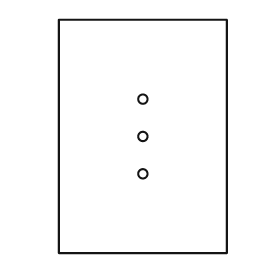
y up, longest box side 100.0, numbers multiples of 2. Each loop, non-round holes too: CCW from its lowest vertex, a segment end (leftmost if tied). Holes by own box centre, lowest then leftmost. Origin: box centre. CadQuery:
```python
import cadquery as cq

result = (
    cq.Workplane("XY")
    .moveTo(-36.0, -50.0)
    .lineTo(36.0, -50.0)
    .lineTo(36.0, 50.0)
    .lineTo(-36.0, 50.0)
    .close()
    .moveTo(0.0, -16.0)
    .circle(2.0)
    .moveTo(0.0, 0.0)
    .circle(2.0)
    .moveTo(0.0, 16.0)
    .circle(2.0)
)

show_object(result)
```